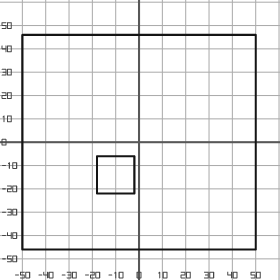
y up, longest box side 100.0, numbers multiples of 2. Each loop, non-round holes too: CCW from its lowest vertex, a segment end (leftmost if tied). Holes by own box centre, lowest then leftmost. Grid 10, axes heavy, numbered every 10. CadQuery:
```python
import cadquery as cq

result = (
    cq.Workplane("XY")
    .moveTo(-50.0, -46.0)
    .lineTo(50.0, -46.0)
    .lineTo(50.0, 46.0)
    .lineTo(-50.0, 46.0)
    .close()
    .moveTo(-18.0, -22.0)
    .lineTo(-2.0, -22.0)
    .lineTo(-2.0, -6.0)
    .lineTo(-18.0, -6.0)
    .close()
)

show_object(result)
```